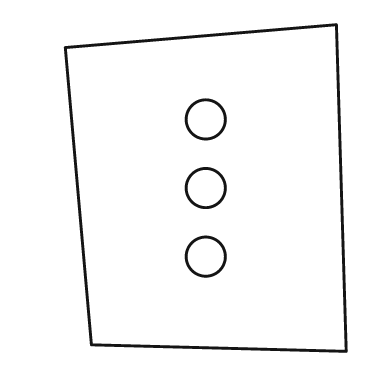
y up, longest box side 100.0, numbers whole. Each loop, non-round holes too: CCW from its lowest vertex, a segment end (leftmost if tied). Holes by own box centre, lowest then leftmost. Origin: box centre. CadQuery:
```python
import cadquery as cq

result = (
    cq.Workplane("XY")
    .moveTo(43.0, -50.0)
    .lineTo(40.0, 50.0)
    .lineTo(-43.0, 43.0)
    .lineTo(-35.0, -48.0)
    .close()
    .moveTo(0.0, -21.0)
    .circle(6.0)
    .moveTo(0.0, 0.0)
    .circle(6.0)
    .moveTo(0.0, 21.0)
    .circle(6.0)
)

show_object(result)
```